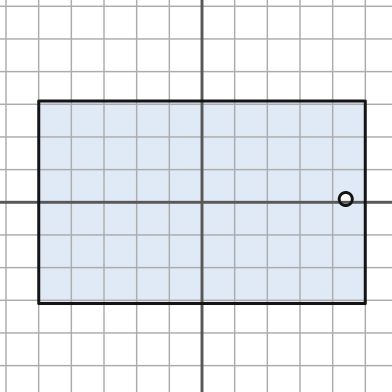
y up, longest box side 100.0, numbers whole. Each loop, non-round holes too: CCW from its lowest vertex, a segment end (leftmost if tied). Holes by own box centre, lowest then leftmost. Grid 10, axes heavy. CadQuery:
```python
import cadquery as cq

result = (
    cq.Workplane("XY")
    .moveTo(-50.0, -31.0)
    .lineTo(50.0, -31.0)
    .lineTo(50.0, 31.0)
    .lineTo(-50.0, 31.0)
    .close()
    .moveTo(44.0, 1.0)
    .circle(2.0)
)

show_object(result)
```